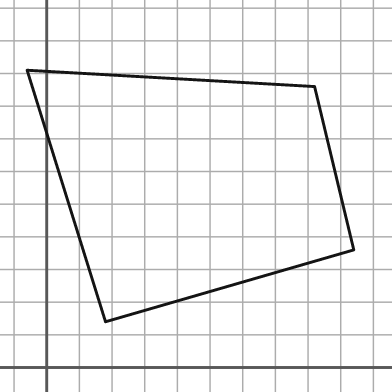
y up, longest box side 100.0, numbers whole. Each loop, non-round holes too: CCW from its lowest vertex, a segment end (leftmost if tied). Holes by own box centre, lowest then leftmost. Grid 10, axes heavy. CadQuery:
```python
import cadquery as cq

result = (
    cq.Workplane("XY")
    .moveTo(18.0, 14.0)
    .lineTo(94.0, 36.0)
    .lineTo(82.0, 86.0)
    .lineTo(-6.0, 91.0)
    .close()
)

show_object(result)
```